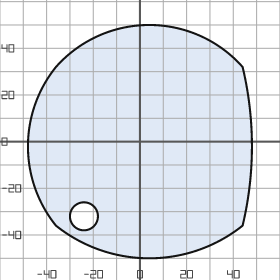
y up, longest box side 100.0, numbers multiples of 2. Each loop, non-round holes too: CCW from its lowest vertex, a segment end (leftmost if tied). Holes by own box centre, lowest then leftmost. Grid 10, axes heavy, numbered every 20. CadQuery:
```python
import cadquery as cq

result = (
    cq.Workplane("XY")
    .moveTo(-36.0, -36.0)
    .threePointArc((4.0, -50.0), (44.0, -36.0))
    .threePointArc((48.0, -2.0), (44.0, 32.0))
    .threePointArc((4.0, 50.0), (-36.0, 32.0))
    .threePointArc((-48.0, -2.0), (-36.0, -36.0))
    .close()
    .moveTo(-24.0, -32.0)
    .circle(6.0)
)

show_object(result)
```